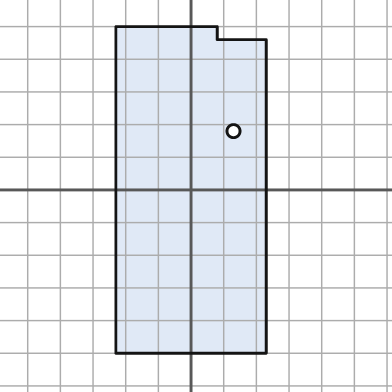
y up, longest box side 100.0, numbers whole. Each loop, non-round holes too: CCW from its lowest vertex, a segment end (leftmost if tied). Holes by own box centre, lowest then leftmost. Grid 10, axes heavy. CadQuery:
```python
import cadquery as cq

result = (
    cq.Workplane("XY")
    .moveTo(-23.0, -50.0)
    .lineTo(23.0, -50.0)
    .lineTo(23.0, 46.0)
    .lineTo(8.0, 46.0)
    .lineTo(8.0, 50.0)
    .lineTo(-23.0, 50.0)
    .close()
    .moveTo(13.0, 18.0)
    .circle(2.0)
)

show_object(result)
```